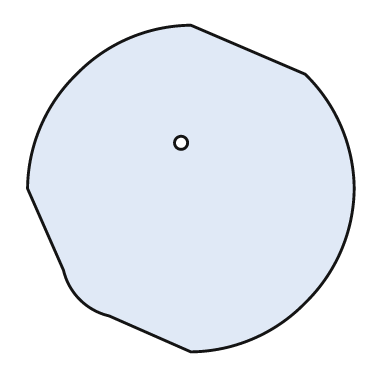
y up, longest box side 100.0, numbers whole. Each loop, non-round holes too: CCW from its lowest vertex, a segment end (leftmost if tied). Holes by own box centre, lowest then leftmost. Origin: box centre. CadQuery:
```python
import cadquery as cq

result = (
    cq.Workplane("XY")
    .moveTo(0.0, -50.0)
    .threePointArc((19.0, -46.0), (35.0, -35.0))
    .threePointArc((46.0, -19.0), (50.0, 0.0))
    .threePointArc((46.0, 19.0), (35.0, 35.0))
    .lineTo(0.0, 50.0)
    .threePointArc((-19.0, 46.0), (-35.0, 35.0))
    .threePointArc((-46.0, 19.0), (-50.0, 0.0))
    .lineTo(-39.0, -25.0)
    .threePointArc((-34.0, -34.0), (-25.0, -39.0))
    .close()
    .moveTo(-3.0, 14.0)
    .circle(2.0)
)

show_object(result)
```